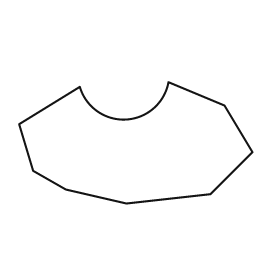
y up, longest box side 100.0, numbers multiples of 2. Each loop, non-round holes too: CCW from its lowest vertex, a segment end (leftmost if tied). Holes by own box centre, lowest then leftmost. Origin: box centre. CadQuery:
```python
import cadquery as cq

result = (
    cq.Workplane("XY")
    .moveTo(-4.0, -26.0)
    .lineTo(32.0, -22.0)
    .lineTo(50.0, -4.0)
    .lineTo(38.0, 16.0)
    .lineTo(14.0, 26.0)
    .threePointArc((-4.0, 10.0), (-24.0, 24.0))
    .lineTo(-50.0, 8.0)
    .lineTo(-44.0, -12.0)
    .lineTo(-30.0, -20.0)
    .close()
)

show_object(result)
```